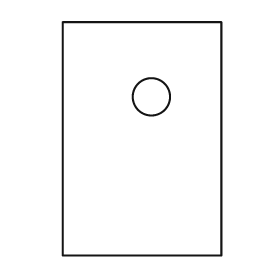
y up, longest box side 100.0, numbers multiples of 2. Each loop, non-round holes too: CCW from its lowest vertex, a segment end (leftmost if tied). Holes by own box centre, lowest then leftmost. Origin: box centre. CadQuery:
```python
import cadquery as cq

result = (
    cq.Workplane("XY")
    .moveTo(-34.0, -50.0)
    .lineTo(34.0, -50.0)
    .lineTo(34.0, 50.0)
    .lineTo(-34.0, 50.0)
    .close()
    .moveTo(4.0, 18.0)
    .circle(8.0)
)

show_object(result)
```